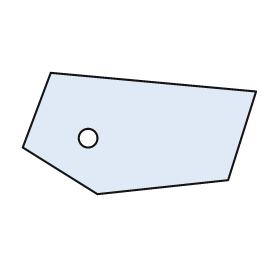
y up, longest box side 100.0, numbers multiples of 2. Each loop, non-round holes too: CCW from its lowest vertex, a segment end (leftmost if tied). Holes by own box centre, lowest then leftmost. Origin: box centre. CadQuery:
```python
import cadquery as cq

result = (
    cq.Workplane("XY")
    .moveTo(-18.0, -26.0)
    .lineTo(38.0, -20.0)
    .lineTo(50.0, 18.0)
    .lineTo(-38.0, 26.0)
    .lineTo(-50.0, -6.0)
    .close()
    .moveTo(-22.0, -2.0)
    .circle(4.0)
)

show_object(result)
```